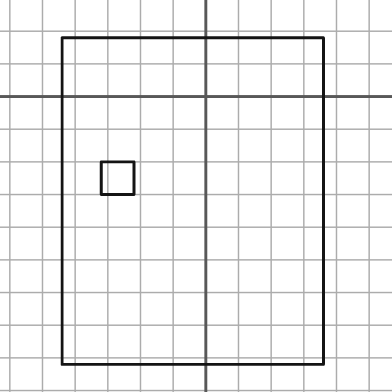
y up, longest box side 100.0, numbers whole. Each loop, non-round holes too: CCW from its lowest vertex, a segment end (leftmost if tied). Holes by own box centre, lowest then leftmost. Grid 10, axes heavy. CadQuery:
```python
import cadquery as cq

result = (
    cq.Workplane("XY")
    .moveTo(-44.0, -82.0)
    .lineTo(36.0, -82.0)
    .lineTo(36.0, 18.0)
    .lineTo(-44.0, 18.0)
    .close()
    .moveTo(-32.0, -30.0)
    .lineTo(-22.0, -30.0)
    .lineTo(-22.0, -20.0)
    .lineTo(-32.0, -20.0)
    .close()
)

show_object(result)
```